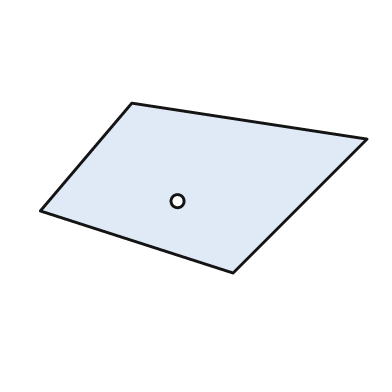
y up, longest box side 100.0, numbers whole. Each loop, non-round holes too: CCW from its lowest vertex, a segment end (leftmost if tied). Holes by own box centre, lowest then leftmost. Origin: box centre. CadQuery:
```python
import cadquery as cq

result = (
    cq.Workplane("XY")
    .moveTo(9.0, -26.0)
    .lineTo(50.0, 15.0)
    .lineTo(-22.0, 26.0)
    .lineTo(-50.0, -7.0)
    .close()
    .moveTo(-8.0, -4.0)
    .circle(2.0)
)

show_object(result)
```